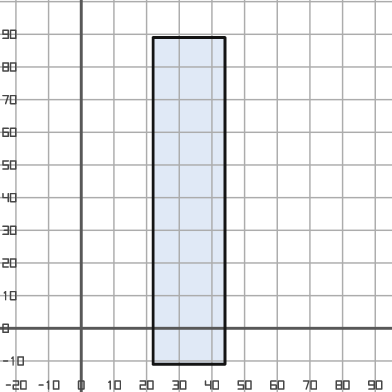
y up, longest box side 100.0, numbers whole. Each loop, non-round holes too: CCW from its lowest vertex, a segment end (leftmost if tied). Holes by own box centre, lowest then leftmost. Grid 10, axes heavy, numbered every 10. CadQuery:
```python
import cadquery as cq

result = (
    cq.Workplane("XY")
    .moveTo(22.0, -11.0)
    .lineTo(44.0, -11.0)
    .lineTo(44.0, 89.0)
    .lineTo(22.0, 89.0)
    .close()
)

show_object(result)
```